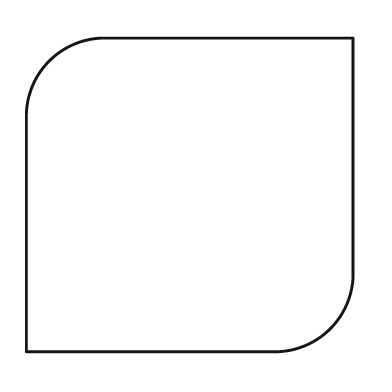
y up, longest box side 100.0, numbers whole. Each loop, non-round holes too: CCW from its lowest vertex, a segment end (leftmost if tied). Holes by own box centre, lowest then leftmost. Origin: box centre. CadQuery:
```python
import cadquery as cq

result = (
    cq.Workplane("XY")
    .moveTo(-50.0, -48.0)
    .lineTo(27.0, -48.0)
    .threePointArc((43.0, -41.0), (50.0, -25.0))
    .lineTo(50.0, 48.0)
    .lineTo(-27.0, 48.0)
    .threePointArc((-43.0, 41.0), (-50.0, 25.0))
    .close()
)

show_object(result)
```